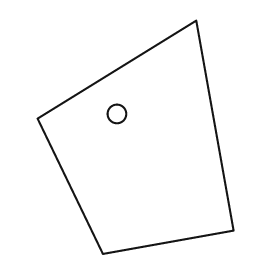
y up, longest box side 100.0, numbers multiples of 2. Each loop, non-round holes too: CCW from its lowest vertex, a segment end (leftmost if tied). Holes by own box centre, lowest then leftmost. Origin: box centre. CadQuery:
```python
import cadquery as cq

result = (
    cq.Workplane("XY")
    .moveTo(-14.0, -50.0)
    .lineTo(42.0, -40.0)
    .lineTo(26.0, 50.0)
    .lineTo(-42.0, 8.0)
    .close()
    .moveTo(-8.0, 10.0)
    .circle(4.0)
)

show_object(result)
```